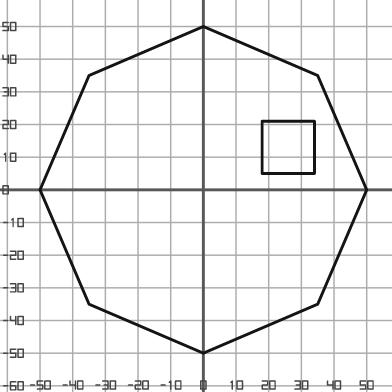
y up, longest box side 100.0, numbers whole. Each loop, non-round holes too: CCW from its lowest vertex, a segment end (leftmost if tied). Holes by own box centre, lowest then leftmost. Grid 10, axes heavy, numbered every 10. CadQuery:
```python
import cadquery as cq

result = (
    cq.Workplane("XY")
    .moveTo(0.0, -50.0)
    .lineTo(35.0, -35.0)
    .lineTo(50.0, 0.0)
    .lineTo(35.0, 35.0)
    .lineTo(0.0, 50.0)
    .lineTo(-35.0, 35.0)
    .lineTo(-50.0, 0.0)
    .lineTo(-35.0, -35.0)
    .close()
    .moveTo(18.0, 5.0)
    .lineTo(34.0, 5.0)
    .lineTo(34.0, 21.0)
    .lineTo(18.0, 21.0)
    .close()
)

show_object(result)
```